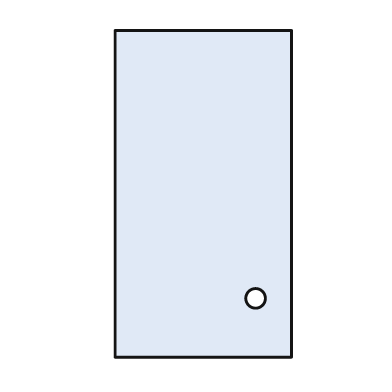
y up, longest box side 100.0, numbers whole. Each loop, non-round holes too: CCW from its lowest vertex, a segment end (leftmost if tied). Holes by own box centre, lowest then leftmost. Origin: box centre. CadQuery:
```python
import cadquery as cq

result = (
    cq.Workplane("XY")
    .moveTo(-27.0, -50.0)
    .lineTo(27.0, -50.0)
    .lineTo(27.0, 50.0)
    .lineTo(-27.0, 50.0)
    .close()
    .moveTo(16.0, -32.0)
    .circle(3.0)
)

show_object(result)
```